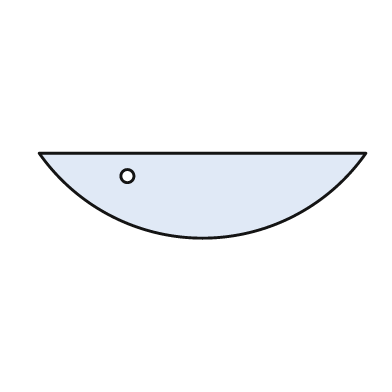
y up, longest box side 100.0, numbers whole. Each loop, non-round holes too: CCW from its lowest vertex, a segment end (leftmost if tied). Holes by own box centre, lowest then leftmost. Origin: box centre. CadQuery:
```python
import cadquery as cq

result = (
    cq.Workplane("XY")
    .moveTo(-50.0, 13.0)
    .threePointArc((0.0, -13.0), (50.0, 13.0))
    .close()
    .moveTo(-23.0, 6.0)
    .circle(2.0)
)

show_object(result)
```